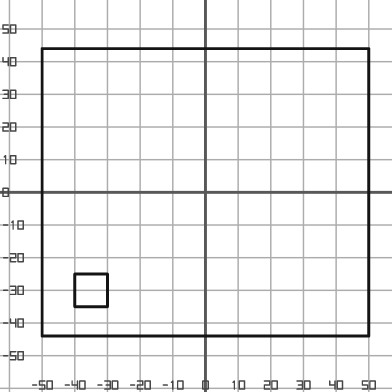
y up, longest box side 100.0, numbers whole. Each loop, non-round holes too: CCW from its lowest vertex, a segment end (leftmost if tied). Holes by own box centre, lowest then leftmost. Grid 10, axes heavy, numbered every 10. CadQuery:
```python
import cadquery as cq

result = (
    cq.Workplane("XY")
    .moveTo(-50.0, -44.0)
    .lineTo(50.0, -44.0)
    .lineTo(50.0, 44.0)
    .lineTo(-50.0, 44.0)
    .close()
    .moveTo(-40.0, -35.0)
    .lineTo(-30.0, -35.0)
    .lineTo(-30.0, -25.0)
    .lineTo(-40.0, -25.0)
    .close()
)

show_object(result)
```